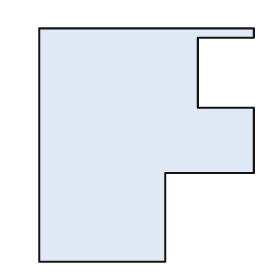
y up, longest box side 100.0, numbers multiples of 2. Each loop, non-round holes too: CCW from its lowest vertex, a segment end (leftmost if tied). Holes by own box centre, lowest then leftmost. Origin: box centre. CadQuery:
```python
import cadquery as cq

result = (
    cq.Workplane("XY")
    .moveTo(-46.0, -50.0)
    .lineTo(8.0, -50.0)
    .lineTo(8.0, -12.0)
    .lineTo(46.0, -12.0)
    .lineTo(46.0, 16.0)
    .lineTo(22.0, 16.0)
    .lineTo(22.0, 46.0)
    .lineTo(46.0, 46.0)
    .lineTo(46.0, 50.0)
    .lineTo(-46.0, 50.0)
    .close()
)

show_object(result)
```